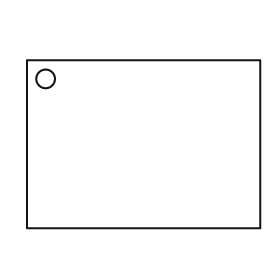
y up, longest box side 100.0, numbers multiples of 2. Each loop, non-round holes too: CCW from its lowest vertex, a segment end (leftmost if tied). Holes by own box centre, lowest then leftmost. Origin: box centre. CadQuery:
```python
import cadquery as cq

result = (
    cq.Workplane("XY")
    .moveTo(-50.0, -36.0)
    .lineTo(50.0, -36.0)
    .lineTo(50.0, 36.0)
    .lineTo(-50.0, 36.0)
    .close()
    .moveTo(-42.0, 28.0)
    .circle(4.0)
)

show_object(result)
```